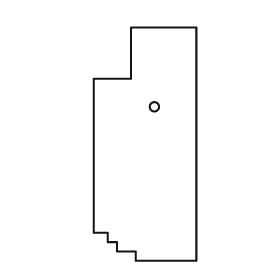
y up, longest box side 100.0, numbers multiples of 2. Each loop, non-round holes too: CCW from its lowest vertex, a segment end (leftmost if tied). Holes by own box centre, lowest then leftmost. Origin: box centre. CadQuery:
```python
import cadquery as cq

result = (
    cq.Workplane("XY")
    .moveTo(-4.0, -50.0)
    .lineTo(22.0, -50.0)
    .lineTo(22.0, 50.0)
    .lineTo(-6.0, 50.0)
    .lineTo(-6.0, 28.0)
    .lineTo(-22.0, 28.0)
    .lineTo(-22.0, -38.0)
    .lineTo(-16.0, -38.0)
    .lineTo(-16.0, -42.0)
    .lineTo(-12.0, -42.0)
    .lineTo(-12.0, -46.0)
    .lineTo(-4.0, -46.0)
    .close()
    .moveTo(4.0, 16.0)
    .circle(2.0)
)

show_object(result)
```